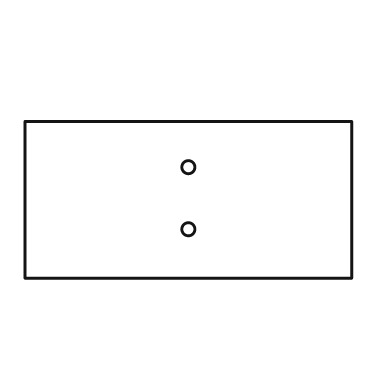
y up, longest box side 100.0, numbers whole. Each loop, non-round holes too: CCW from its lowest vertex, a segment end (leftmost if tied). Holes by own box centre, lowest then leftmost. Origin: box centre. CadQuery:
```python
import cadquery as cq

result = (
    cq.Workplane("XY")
    .moveTo(-50.0, -24.0)
    .lineTo(50.0, -24.0)
    .lineTo(50.0, 24.0)
    .lineTo(-50.0, 24.0)
    .close()
    .moveTo(0.0, -9.0)
    .circle(2.0)
    .moveTo(0.0, 10.0)
    .circle(2.0)
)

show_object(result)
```